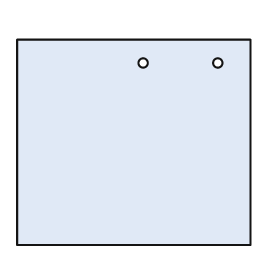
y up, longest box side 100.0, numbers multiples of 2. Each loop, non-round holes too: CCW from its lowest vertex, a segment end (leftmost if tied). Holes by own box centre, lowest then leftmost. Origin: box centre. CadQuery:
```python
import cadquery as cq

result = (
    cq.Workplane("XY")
    .moveTo(-50.0, -44.0)
    .lineTo(50.0, -44.0)
    .lineTo(50.0, 44.0)
    .lineTo(-50.0, 44.0)
    .close()
    .moveTo(4.0, 34.0)
    .circle(2.0)
    .moveTo(36.0, 34.0)
    .circle(2.0)
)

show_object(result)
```